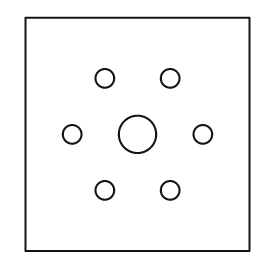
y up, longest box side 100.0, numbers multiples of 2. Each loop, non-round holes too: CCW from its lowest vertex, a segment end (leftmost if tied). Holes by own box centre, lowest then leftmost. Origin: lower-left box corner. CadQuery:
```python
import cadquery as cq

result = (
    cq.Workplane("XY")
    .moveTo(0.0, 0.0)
    .lineTo(96.0, 0.0)
    .lineTo(96.0, 100.0)
    .lineTo(0.0, 100.0)
    .close()
    .moveTo(34.0, 26.0)
    .circle(4.0)
    .moveTo(62.0, 26.0)
    .circle(4.0)
    .moveTo(20.0, 50.0)
    .circle(4.0)
    .moveTo(48.0, 50.0)
    .circle(8.0)
    .moveTo(76.0, 50.0)
    .circle(4.0)
    .moveTo(34.0, 74.0)
    .circle(4.0)
    .moveTo(62.0, 74.0)
    .circle(4.0)
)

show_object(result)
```